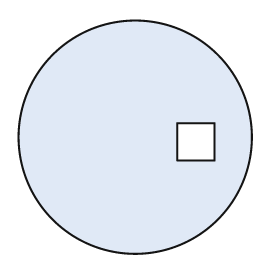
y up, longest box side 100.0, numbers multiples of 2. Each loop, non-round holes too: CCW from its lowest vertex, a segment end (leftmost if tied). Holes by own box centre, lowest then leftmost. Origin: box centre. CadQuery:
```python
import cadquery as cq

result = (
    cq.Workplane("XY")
    .moveTo(0.0, 0.0)
    .circle(50.0)
    .moveTo(18.0, -10.0)
    .lineTo(34.0, -10.0)
    .lineTo(34.0, 6.0)
    .lineTo(18.0, 6.0)
    .close()
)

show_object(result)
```